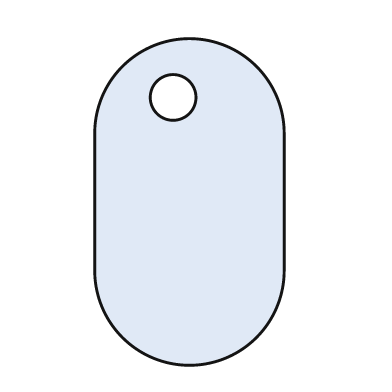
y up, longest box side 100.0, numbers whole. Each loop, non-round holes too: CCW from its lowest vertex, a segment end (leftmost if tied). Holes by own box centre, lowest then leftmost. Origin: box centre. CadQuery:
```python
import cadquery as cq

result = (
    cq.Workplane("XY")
    .moveTo(-29.0, -21.0)
    .threePointArc((0.0, -50.0), (29.0, -21.0))
    .lineTo(29.0, 21.0)
    .threePointArc((0.0, 50.0), (-29.0, 21.0))
    .close()
    .moveTo(-5.0, 32.0)
    .circle(7.0)
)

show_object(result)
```